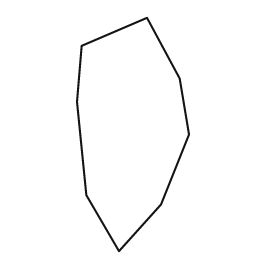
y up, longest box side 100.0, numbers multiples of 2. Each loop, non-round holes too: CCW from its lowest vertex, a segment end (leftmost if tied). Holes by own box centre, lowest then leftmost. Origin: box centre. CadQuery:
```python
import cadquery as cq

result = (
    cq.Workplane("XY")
    .moveTo(-6.0, -50.0)
    .lineTo(12.0, -30.0)
    .lineTo(24.0, 0.0)
    .lineTo(20.0, 24.0)
    .lineTo(6.0, 50.0)
    .lineTo(-22.0, 38.0)
    .lineTo(-24.0, 14.0)
    .lineTo(-20.0, -26.0)
    .close()
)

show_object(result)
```